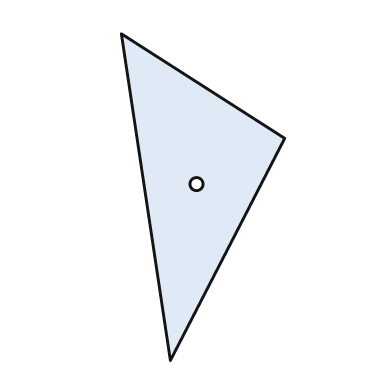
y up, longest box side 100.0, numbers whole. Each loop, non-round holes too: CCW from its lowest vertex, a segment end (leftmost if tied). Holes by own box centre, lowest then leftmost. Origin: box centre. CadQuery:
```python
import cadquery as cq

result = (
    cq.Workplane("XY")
    .moveTo(-10.0, -50.0)
    .lineTo(25.0, 18.0)
    .lineTo(-25.0, 50.0)
    .close()
    .moveTo(-2.0, 4.0)
    .circle(2.0)
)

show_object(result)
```